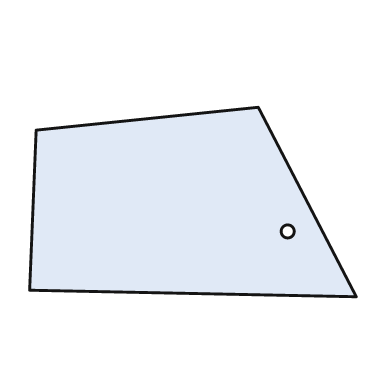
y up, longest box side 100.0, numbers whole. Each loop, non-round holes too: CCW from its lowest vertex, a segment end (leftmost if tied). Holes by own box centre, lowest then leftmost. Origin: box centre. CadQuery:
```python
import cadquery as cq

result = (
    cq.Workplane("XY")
    .moveTo(50.0, -29.0)
    .lineTo(20.0, 29.0)
    .lineTo(-48.0, 22.0)
    .lineTo(-50.0, -27.0)
    .close()
    .moveTo(29.0, -9.0)
    .circle(2.0)
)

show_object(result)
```